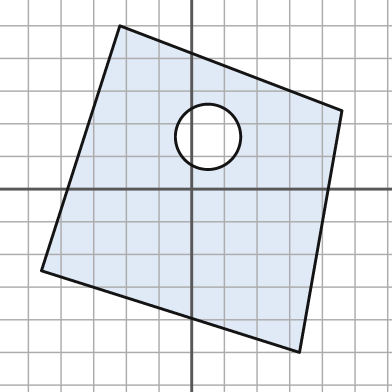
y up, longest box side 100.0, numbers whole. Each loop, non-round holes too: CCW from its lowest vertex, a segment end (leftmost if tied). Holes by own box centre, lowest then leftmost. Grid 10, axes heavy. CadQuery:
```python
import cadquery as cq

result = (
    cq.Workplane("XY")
    .moveTo(33.0, -50.0)
    .lineTo(46.0, 24.0)
    .lineTo(-22.0, 50.0)
    .lineTo(-46.0, -25.0)
    .close()
    .moveTo(5.0, 16.0)
    .circle(10.0)
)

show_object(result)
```